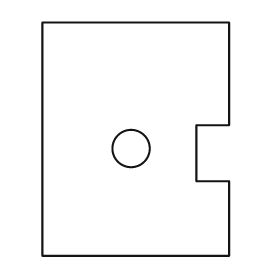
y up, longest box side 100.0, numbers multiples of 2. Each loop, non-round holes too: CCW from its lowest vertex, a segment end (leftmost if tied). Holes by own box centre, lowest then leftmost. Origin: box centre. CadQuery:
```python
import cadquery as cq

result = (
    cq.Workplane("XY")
    .moveTo(-40.0, -50.0)
    .lineTo(40.0, -50.0)
    .lineTo(40.0, -18.0)
    .lineTo(26.0, -18.0)
    .lineTo(26.0, 6.0)
    .lineTo(40.0, 6.0)
    .lineTo(40.0, 50.0)
    .lineTo(-40.0, 50.0)
    .close()
    .moveTo(-2.0, -4.0)
    .circle(8.0)
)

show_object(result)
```